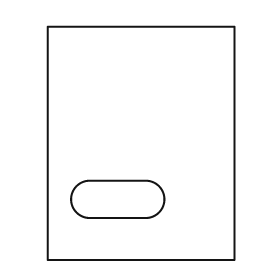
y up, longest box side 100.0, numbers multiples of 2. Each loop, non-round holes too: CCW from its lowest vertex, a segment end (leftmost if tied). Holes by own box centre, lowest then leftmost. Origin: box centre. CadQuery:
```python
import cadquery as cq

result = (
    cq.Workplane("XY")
    .moveTo(-40.0, -50.0)
    .lineTo(40.0, -50.0)
    .lineTo(40.0, 50.0)
    .lineTo(-40.0, 50.0)
    .close()
    .moveTo(-22.0, -32.0)
    .lineTo(2.0, -32.0)
    .threePointArc((10.0, -24.0), (2.0, -16.0))
    .lineTo(-22.0, -16.0)
    .threePointArc((-30.0, -24.0), (-22.0, -32.0))
    .close()
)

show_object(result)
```